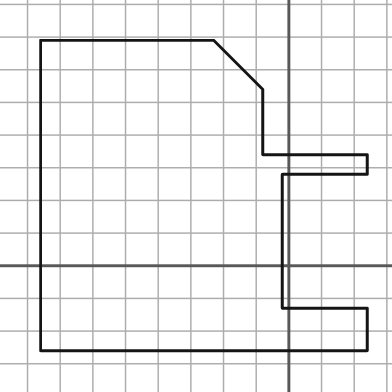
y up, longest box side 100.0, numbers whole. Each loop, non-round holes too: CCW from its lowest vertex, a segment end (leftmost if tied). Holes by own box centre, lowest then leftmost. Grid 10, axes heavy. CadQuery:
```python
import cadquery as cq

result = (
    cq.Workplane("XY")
    .moveTo(-76.0, -26.0)
    .lineTo(24.0, -26.0)
    .lineTo(24.0, -13.0)
    .lineTo(-2.0, -13.0)
    .lineTo(-2.0, 28.0)
    .lineTo(24.0, 28.0)
    .lineTo(24.0, 34.0)
    .lineTo(-8.0, 34.0)
    .lineTo(-8.0, 54.0)
    .lineTo(-23.0, 69.0)
    .lineTo(-76.0, 69.0)
    .close()
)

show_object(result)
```